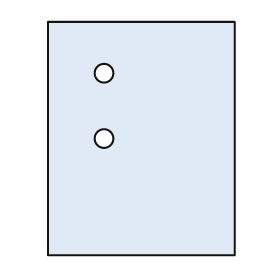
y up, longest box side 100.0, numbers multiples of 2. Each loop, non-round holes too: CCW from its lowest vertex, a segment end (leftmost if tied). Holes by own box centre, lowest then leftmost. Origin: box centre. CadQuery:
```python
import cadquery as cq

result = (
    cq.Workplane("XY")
    .moveTo(-40.0, -50.0)
    .lineTo(40.0, -50.0)
    .lineTo(40.0, 50.0)
    .lineTo(-40.0, 50.0)
    .close()
    .moveTo(-16.0, 0.0)
    .circle(4.0)
    .moveTo(-16.0, 28.0)
    .circle(4.0)
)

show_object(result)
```